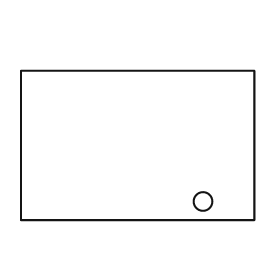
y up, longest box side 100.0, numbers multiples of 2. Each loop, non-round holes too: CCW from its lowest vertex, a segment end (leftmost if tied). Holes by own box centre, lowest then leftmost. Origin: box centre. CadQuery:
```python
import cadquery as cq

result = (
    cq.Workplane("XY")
    .moveTo(-50.0, -32.0)
    .lineTo(50.0, -32.0)
    .lineTo(50.0, 32.0)
    .lineTo(-50.0, 32.0)
    .close()
    .moveTo(28.0, -24.0)
    .circle(4.0)
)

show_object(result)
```